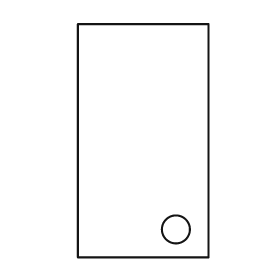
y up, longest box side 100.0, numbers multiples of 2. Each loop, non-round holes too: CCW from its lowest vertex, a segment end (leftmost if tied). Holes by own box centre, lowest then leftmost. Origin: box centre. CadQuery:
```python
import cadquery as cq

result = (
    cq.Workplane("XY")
    .moveTo(-28.0, -50.0)
    .lineTo(28.0, -50.0)
    .lineTo(28.0, 50.0)
    .lineTo(-28.0, 50.0)
    .close()
    .moveTo(14.0, -38.0)
    .circle(6.0)
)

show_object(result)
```